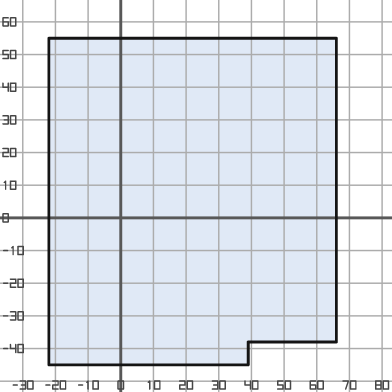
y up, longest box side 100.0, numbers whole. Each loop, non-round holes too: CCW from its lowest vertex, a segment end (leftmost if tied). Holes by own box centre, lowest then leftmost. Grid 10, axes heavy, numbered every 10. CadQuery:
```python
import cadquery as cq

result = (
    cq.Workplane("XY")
    .moveTo(-22.0, -45.0)
    .lineTo(39.0, -45.0)
    .lineTo(39.0, -38.0)
    .lineTo(66.0, -38.0)
    .lineTo(66.0, 55.0)
    .lineTo(-22.0, 55.0)
    .close()
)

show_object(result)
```